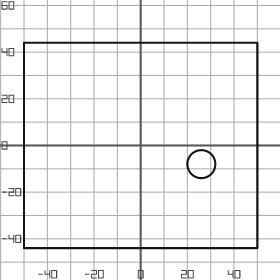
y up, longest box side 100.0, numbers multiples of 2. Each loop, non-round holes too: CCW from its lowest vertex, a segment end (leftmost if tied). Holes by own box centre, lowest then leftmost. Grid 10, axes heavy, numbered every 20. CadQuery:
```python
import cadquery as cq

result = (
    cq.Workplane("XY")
    .moveTo(-50.0, -44.0)
    .lineTo(50.0, -44.0)
    .lineTo(50.0, 44.0)
    .lineTo(-50.0, 44.0)
    .close()
    .moveTo(26.0, -8.0)
    .circle(6.0)
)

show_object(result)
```